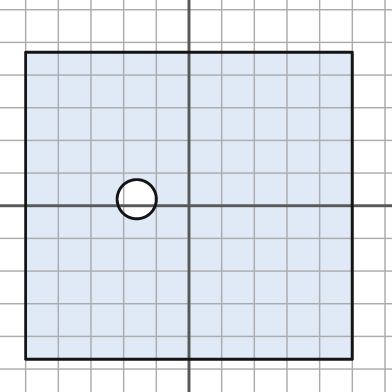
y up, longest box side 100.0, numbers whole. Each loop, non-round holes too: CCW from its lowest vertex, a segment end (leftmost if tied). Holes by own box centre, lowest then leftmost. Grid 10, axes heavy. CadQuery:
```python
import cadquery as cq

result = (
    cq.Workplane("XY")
    .moveTo(-50.0, -47.0)
    .lineTo(50.0, -47.0)
    .lineTo(50.0, 47.0)
    .lineTo(-50.0, 47.0)
    .close()
    .moveTo(-16.0, 2.0)
    .circle(6.0)
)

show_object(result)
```